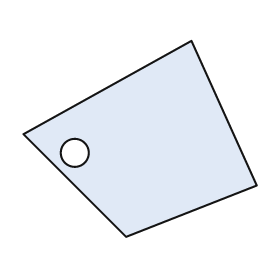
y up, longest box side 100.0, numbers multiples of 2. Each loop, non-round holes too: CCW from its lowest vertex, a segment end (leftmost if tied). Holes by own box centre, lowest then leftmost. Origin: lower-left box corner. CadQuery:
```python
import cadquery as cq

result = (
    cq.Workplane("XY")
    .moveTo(44.0, 0.0)
    .lineTo(100.0, 22.0)
    .lineTo(72.0, 84.0)
    .lineTo(0.0, 44.0)
    .close()
    .moveTo(22.0, 36.0)
    .circle(6.0)
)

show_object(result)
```